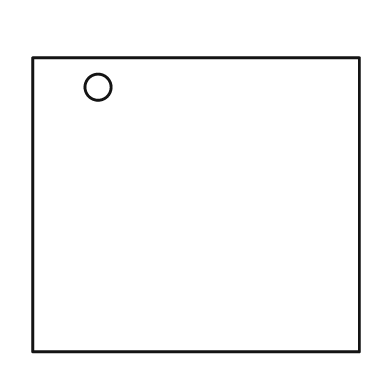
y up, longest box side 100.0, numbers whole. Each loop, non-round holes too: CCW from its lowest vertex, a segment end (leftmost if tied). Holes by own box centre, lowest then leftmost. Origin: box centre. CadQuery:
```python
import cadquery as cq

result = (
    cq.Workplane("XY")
    .moveTo(-50.0, -45.0)
    .lineTo(50.0, -45.0)
    .lineTo(50.0, 45.0)
    .lineTo(-50.0, 45.0)
    .close()
    .moveTo(-30.0, 36.0)
    .circle(4.0)
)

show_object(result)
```